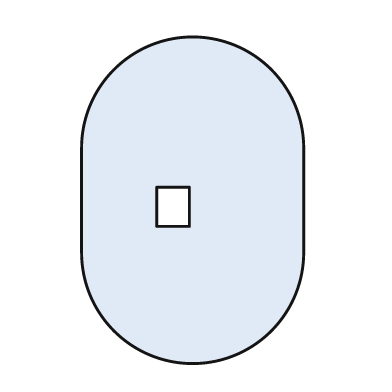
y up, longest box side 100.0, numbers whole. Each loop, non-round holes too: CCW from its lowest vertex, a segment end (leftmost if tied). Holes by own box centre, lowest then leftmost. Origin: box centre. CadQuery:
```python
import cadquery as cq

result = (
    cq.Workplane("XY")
    .moveTo(-34.0, -16.0)
    .threePointArc((0.0, -50.0), (34.0, -16.0))
    .lineTo(34.0, 16.0)
    .threePointArc((0.0, 50.0), (-34.0, 16.0))
    .close()
    .moveTo(-11.0, -8.0)
    .lineTo(-1.0, -8.0)
    .lineTo(-1.0, 4.0)
    .lineTo(-11.0, 4.0)
    .close()
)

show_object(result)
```